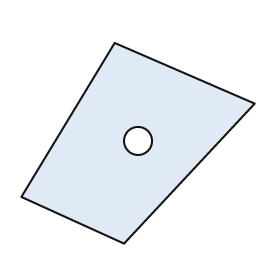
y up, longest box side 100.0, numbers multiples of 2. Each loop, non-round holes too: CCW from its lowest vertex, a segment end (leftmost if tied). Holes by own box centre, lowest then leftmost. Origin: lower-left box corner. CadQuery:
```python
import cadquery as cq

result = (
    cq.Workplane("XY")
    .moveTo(44.0, 0.0)
    .lineTo(100.0, 60.0)
    .lineTo(40.0, 86.0)
    .lineTo(0.0, 20.0)
    .close()
    .moveTo(50.0, 44.0)
    .circle(6.0)
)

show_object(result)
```